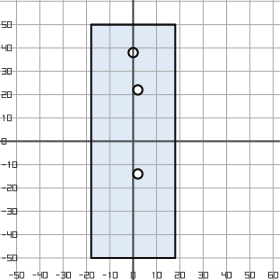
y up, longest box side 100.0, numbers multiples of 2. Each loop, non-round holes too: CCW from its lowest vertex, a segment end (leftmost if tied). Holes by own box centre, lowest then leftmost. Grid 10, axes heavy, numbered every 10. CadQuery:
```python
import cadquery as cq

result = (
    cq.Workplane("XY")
    .moveTo(-18.0, -50.0)
    .lineTo(18.0, -50.0)
    .lineTo(18.0, 50.0)
    .lineTo(-18.0, 50.0)
    .close()
    .moveTo(2.0, -14.0)
    .circle(2.0)
    .moveTo(2.0, 22.0)
    .circle(2.0)
    .moveTo(0.0, 38.0)
    .circle(2.0)
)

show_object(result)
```